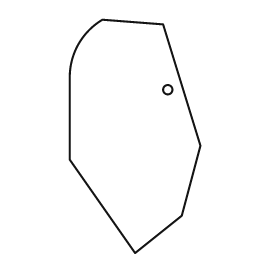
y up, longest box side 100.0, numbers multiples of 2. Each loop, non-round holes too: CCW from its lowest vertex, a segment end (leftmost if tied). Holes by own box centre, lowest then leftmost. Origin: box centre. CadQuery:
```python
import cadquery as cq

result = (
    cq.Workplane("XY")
    .moveTo(0.0, -50.0)
    .lineTo(20.0, -34.0)
    .lineTo(28.0, -4.0)
    .lineTo(12.0, 48.0)
    .lineTo(-14.0, 50.0)
    .threePointArc((-24.0, 40.0), (-28.0, 26.0))
    .lineTo(-28.0, -10.0)
    .close()
    .moveTo(14.0, 20.0)
    .circle(2.0)
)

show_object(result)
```